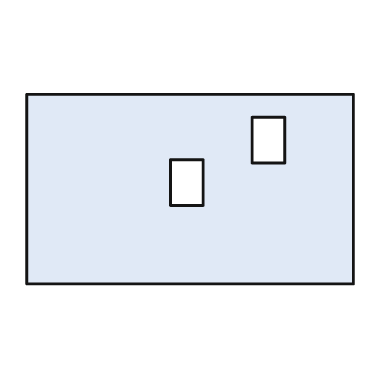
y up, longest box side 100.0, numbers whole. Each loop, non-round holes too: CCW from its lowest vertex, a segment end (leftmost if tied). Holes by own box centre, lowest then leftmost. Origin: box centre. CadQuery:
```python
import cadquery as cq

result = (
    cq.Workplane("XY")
    .moveTo(-50.0, -29.0)
    .lineTo(50.0, -29.0)
    .lineTo(50.0, 29.0)
    .lineTo(-50.0, 29.0)
    .close()
    .moveTo(-6.0, -5.0)
    .lineTo(4.0, -5.0)
    .lineTo(4.0, 9.0)
    .lineTo(-6.0, 9.0)
    .close()
    .moveTo(19.0, 8.0)
    .lineTo(29.0, 8.0)
    .lineTo(29.0, 22.0)
    .lineTo(19.0, 22.0)
    .close()
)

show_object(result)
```